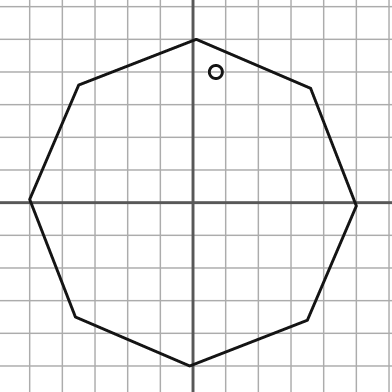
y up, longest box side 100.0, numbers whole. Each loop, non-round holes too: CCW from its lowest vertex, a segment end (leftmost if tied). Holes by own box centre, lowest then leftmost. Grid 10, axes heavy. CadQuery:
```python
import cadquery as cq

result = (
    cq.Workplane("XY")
    .moveTo(-1.0, -50.0)
    .lineTo(35.0, -36.0)
    .lineTo(50.0, -1.0)
    .lineTo(36.0, 35.0)
    .lineTo(1.0, 50.0)
    .lineTo(-35.0, 36.0)
    .lineTo(-50.0, 1.0)
    .lineTo(-36.0, -35.0)
    .close()
    .moveTo(7.0, 40.0)
    .circle(2.0)
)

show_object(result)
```